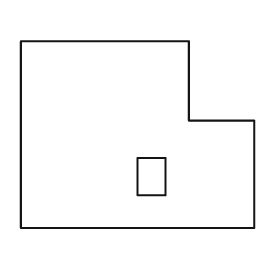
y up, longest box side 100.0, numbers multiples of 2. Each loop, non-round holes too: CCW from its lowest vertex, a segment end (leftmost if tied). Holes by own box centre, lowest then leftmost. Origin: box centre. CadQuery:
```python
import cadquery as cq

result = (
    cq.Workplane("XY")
    .moveTo(-50.0, -40.0)
    .lineTo(50.0, -40.0)
    .lineTo(50.0, 6.0)
    .lineTo(22.0, 6.0)
    .lineTo(22.0, 40.0)
    .lineTo(-50.0, 40.0)
    .close()
    .moveTo(0.0, -26.0)
    .lineTo(12.0, -26.0)
    .lineTo(12.0, -10.0)
    .lineTo(0.0, -10.0)
    .close()
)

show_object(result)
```